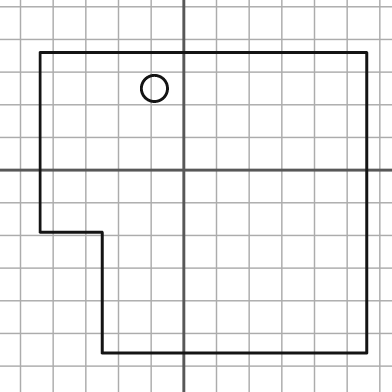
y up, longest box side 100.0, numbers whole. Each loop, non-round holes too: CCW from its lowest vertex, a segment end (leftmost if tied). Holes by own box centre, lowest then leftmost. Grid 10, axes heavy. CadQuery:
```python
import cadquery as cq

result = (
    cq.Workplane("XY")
    .moveTo(-25.0, -56.0)
    .lineTo(56.0, -56.0)
    .lineTo(56.0, 36.0)
    .lineTo(-44.0, 36.0)
    .lineTo(-44.0, -19.0)
    .lineTo(-25.0, -19.0)
    .close()
    .moveTo(-9.0, 25.0)
    .circle(4.0)
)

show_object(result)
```